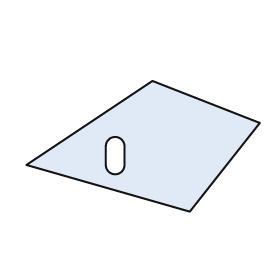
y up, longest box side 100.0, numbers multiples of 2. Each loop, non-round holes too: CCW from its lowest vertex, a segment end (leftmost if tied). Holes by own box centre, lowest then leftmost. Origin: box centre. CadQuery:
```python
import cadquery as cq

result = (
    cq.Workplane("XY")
    .moveTo(20.0, -28.0)
    .lineTo(50.0, 10.0)
    .lineTo(4.0, 28.0)
    .lineTo(-50.0, -8.0)
    .close()
    .moveTo(-16.0, -8.0)
    .threePointArc((-12.0, -12.0), (-8.0, -8.0))
    .lineTo(-8.0, 0.0)
    .threePointArc((-12.0, 4.0), (-16.0, 0.0))
    .close()
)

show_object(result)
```